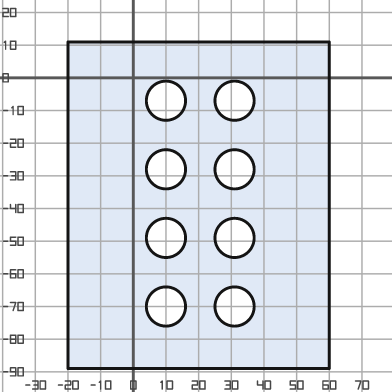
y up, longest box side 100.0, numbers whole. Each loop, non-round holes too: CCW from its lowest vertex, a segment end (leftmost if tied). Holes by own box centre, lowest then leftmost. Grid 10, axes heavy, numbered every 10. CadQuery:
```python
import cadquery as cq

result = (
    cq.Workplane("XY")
    .moveTo(-20.0, -89.0)
    .lineTo(60.0, -89.0)
    .lineTo(60.0, 11.0)
    .lineTo(-20.0, 11.0)
    .close()
    .moveTo(10.0, -70.0)
    .circle(6.0)
    .moveTo(31.0, -70.0)
    .circle(6.0)
    .moveTo(10.0, -49.0)
    .circle(6.0)
    .moveTo(31.0, -49.0)
    .circle(6.0)
    .moveTo(10.0, -28.0)
    .circle(6.0)
    .moveTo(31.0, -28.0)
    .circle(6.0)
    .moveTo(10.0, -7.0)
    .circle(6.0)
    .moveTo(31.0, -7.0)
    .circle(6.0)
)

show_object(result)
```